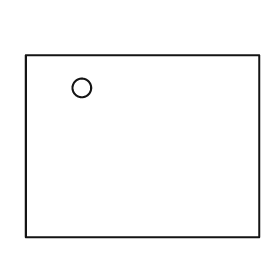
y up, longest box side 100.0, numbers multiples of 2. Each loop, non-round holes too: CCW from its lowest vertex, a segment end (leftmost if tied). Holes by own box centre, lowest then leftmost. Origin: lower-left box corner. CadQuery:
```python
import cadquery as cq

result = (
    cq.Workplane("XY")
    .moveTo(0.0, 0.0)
    .lineTo(100.0, 0.0)
    .lineTo(100.0, 78.0)
    .lineTo(0.0, 78.0)
    .close()
    .moveTo(24.0, 64.0)
    .circle(4.0)
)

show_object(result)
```